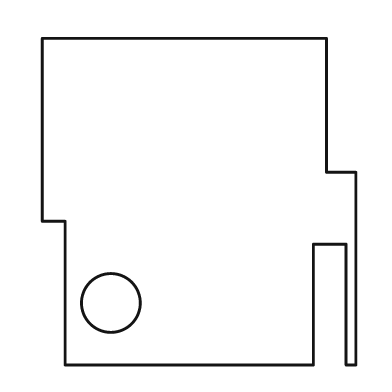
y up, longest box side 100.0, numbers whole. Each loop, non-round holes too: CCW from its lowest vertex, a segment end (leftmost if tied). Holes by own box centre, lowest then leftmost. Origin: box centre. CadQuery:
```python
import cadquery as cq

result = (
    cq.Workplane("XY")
    .moveTo(-41.0, -50.0)
    .lineTo(35.0, -50.0)
    .lineTo(35.0, -13.0)
    .lineTo(45.0, -13.0)
    .lineTo(45.0, -50.0)
    .lineTo(48.0, -50.0)
    .lineTo(48.0, 9.0)
    .lineTo(39.0, 9.0)
    .lineTo(39.0, 50.0)
    .lineTo(-48.0, 50.0)
    .lineTo(-48.0, -6.0)
    .lineTo(-41.0, -6.0)
    .close()
    .moveTo(-27.0, -31.0)
    .circle(9.0)
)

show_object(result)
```